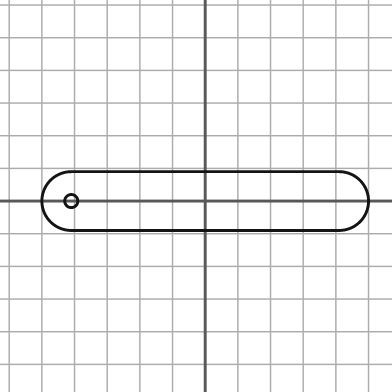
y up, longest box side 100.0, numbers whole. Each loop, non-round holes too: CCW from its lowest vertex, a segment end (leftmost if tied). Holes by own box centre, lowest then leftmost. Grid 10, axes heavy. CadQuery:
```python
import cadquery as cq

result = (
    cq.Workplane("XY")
    .moveTo(-41.0, -9.0)
    .lineTo(41.0, -9.0)
    .threePointArc((50.0, 0.0), (41.0, 9.0))
    .lineTo(-41.0, 9.0)
    .threePointArc((-50.0, 0.0), (-41.0, -9.0))
    .close()
    .moveTo(-41.0, 0.0)
    .circle(2.0)
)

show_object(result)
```